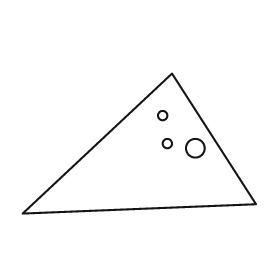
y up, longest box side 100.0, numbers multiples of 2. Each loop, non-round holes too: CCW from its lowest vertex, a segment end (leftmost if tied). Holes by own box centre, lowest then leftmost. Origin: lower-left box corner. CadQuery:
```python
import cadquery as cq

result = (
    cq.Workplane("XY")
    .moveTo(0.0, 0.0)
    .lineTo(100.0, 4.0)
    .lineTo(64.0, 60.0)
    .close()
    .moveTo(74.0, 28.0)
    .circle(4.0)
    .moveTo(62.0, 30.0)
    .circle(2.0)
    .moveTo(60.0, 42.0)
    .circle(2.0)
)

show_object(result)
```